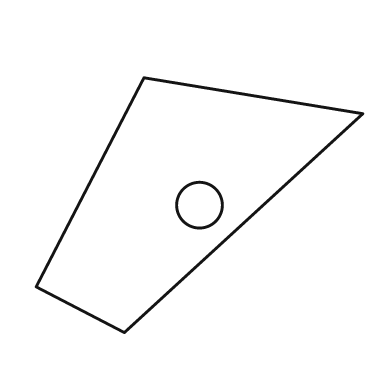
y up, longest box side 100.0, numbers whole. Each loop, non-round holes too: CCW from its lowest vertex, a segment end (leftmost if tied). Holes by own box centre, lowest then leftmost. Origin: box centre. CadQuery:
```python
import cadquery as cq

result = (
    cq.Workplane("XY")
    .moveTo(-23.0, -39.0)
    .lineTo(50.0, 28.0)
    .lineTo(-17.0, 39.0)
    .lineTo(-50.0, -25.0)
    .close()
    .moveTo(0.0, 0.0)
    .circle(7.0)
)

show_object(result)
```